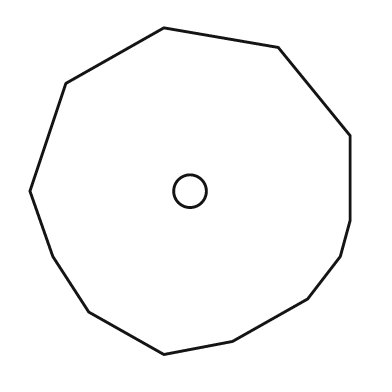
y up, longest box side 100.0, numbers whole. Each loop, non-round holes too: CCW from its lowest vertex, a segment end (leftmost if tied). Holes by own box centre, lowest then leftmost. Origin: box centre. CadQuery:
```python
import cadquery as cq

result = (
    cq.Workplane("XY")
    .moveTo(-8.0, -50.0)
    .lineTo(13.0, -46.0)
    .lineTo(36.0, -33.0)
    .lineTo(46.0, -20.0)
    .lineTo(49.0, -9.0)
    .lineTo(49.0, 17.0)
    .lineTo(27.0, 44.0)
    .lineTo(-8.0, 50.0)
    .lineTo(-38.0, 33.0)
    .lineTo(-49.0, 0.0)
    .lineTo(-42.0, -20.0)
    .lineTo(-31.0, -37.0)
    .close()
    .moveTo(0.0, 0.0)
    .circle(5.0)
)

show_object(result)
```